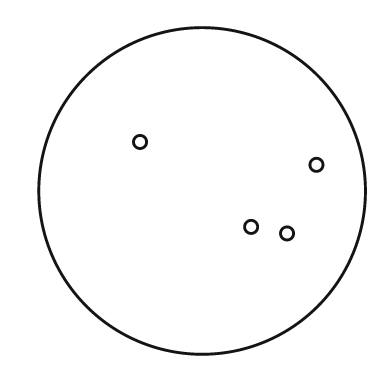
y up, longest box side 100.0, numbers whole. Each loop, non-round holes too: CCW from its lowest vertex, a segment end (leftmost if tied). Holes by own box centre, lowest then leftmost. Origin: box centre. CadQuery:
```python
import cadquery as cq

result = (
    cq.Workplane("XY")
    .moveTo(0.0, 0.0)
    .circle(50.0)
    .moveTo(26.0, -13.0)
    .circle(2.0)
    .moveTo(15.0, -11.0)
    .circle(2.0)
    .moveTo(35.0, 8.0)
    .circle(2.0)
    .moveTo(-19.0, 15.0)
    .circle(2.0)
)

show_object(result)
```